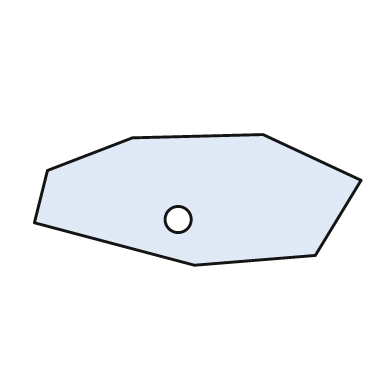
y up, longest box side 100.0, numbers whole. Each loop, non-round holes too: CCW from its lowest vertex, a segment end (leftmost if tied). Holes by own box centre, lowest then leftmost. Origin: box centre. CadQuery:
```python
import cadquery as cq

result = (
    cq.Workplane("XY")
    .moveTo(-1.0, -20.0)
    .lineTo(36.0, -17.0)
    .lineTo(50.0, 6.0)
    .lineTo(20.0, 20.0)
    .lineTo(-20.0, 19.0)
    .lineTo(-46.0, 9.0)
    .lineTo(-50.0, -7.0)
    .close()
    .moveTo(-6.0, -6.0)
    .circle(4.0)
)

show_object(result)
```